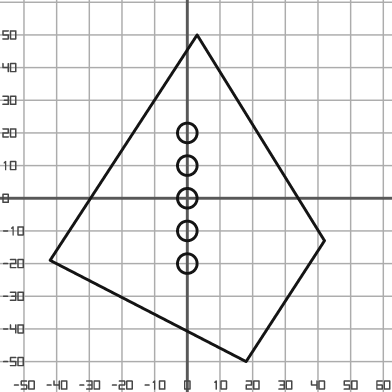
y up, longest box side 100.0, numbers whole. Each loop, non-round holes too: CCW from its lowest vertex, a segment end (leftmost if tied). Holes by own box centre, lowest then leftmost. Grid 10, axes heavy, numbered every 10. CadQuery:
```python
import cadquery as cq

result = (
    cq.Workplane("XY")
    .moveTo(18.0, -50.0)
    .lineTo(42.0, -13.0)
    .lineTo(3.0, 50.0)
    .lineTo(-42.0, -19.0)
    .close()
    .moveTo(0.0, -20.0)
    .circle(3.0)
    .moveTo(0.0, -10.0)
    .circle(3.0)
    .moveTo(0.0, 0.0)
    .circle(3.0)
    .moveTo(0.0, 10.0)
    .circle(3.0)
    .moveTo(0.0, 20.0)
    .circle(3.0)
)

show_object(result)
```